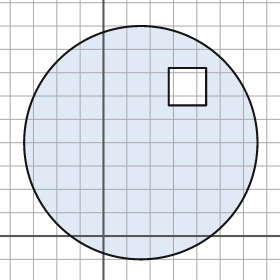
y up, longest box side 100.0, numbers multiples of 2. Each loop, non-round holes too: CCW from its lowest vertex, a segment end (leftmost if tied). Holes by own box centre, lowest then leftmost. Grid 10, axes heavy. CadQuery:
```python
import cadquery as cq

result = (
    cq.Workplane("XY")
    .moveTo(16.0, 40.0)
    .circle(50.0)
    .moveTo(28.0, 56.0)
    .lineTo(44.0, 56.0)
    .lineTo(44.0, 72.0)
    .lineTo(28.0, 72.0)
    .close()
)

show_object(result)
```